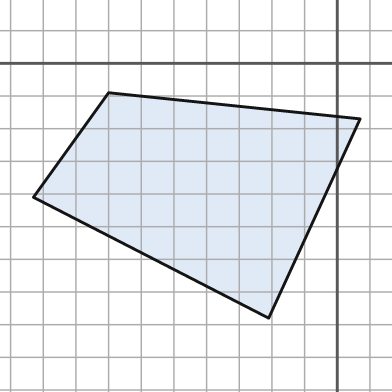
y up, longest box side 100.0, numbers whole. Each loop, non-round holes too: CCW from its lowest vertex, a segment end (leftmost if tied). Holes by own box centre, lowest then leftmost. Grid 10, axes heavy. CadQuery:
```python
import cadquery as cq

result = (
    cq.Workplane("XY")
    .moveTo(-21.0, -78.0)
    .lineTo(7.0, -17.0)
    .lineTo(-70.0, -9.0)
    .lineTo(-93.0, -41.0)
    .close()
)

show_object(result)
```